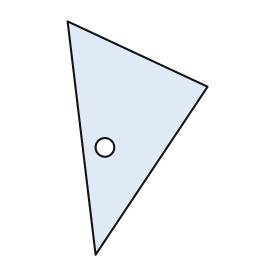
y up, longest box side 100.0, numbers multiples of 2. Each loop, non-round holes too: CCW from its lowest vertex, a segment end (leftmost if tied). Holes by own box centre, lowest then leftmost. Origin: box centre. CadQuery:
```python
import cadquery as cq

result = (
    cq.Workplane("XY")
    .moveTo(-18.0, -50.0)
    .lineTo(30.0, 22.0)
    .lineTo(-30.0, 50.0)
    .close()
    .moveTo(-14.0, -4.0)
    .circle(4.0)
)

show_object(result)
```